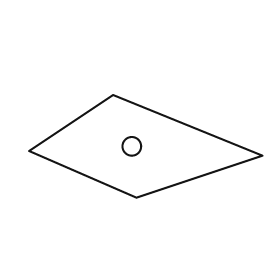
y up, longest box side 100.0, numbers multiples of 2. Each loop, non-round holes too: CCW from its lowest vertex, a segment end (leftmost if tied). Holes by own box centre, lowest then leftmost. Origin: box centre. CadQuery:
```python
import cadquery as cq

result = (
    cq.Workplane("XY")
    .moveTo(-4.0, -22.0)
    .lineTo(50.0, -4.0)
    .lineTo(-14.0, 22.0)
    .lineTo(-50.0, -2.0)
    .close()
    .moveTo(-6.0, 0.0)
    .circle(4.0)
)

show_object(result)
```